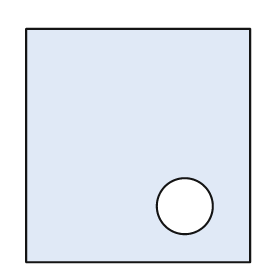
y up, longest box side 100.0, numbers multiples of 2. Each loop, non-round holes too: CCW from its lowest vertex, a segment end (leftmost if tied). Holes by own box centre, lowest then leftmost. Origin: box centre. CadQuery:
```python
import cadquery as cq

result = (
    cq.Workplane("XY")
    .moveTo(-48.0, -50.0)
    .lineTo(48.0, -50.0)
    .lineTo(48.0, 50.0)
    .lineTo(-48.0, 50.0)
    .close()
    .moveTo(20.0, -26.0)
    .circle(12.0)
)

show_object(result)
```